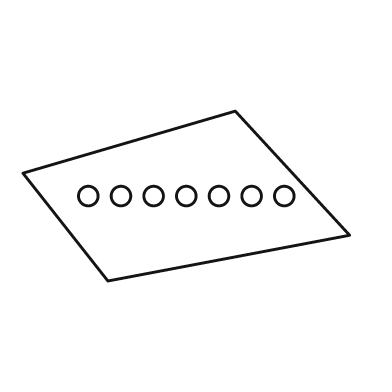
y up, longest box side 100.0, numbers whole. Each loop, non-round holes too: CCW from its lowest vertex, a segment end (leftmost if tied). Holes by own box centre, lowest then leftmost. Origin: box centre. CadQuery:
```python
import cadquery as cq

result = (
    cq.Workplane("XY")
    .moveTo(-24.0, -26.0)
    .lineTo(50.0, -12.0)
    .lineTo(15.0, 26.0)
    .lineTo(-50.0, 7.0)
    .close()
    .moveTo(-30.0, 0.0)
    .circle(3.0)
    .moveTo(-20.0, 0.0)
    .circle(3.0)
    .moveTo(-10.0, 0.0)
    .circle(3.0)
    .moveTo(0.0, 0.0)
    .circle(3.0)
    .moveTo(10.0, 0.0)
    .circle(3.0)
    .moveTo(20.0, 0.0)
    .circle(3.0)
    .moveTo(30.0, 0.0)
    .circle(3.0)
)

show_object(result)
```